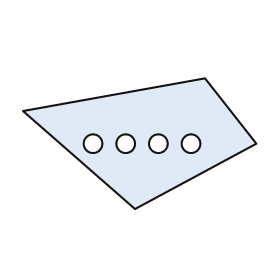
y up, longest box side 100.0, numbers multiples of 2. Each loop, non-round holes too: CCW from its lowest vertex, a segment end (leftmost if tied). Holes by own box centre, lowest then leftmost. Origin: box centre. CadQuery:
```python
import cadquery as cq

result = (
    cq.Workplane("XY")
    .moveTo(-2.0, -28.0)
    .lineTo(50.0, 0.0)
    .lineTo(28.0, 28.0)
    .lineTo(-50.0, 14.0)
    .close()
    .moveTo(-20.0, 0.0)
    .circle(4.0)
    .moveTo(-6.0, 0.0)
    .circle(4.0)
    .moveTo(8.0, 0.0)
    .circle(4.0)
    .moveTo(22.0, 0.0)
    .circle(4.0)
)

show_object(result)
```